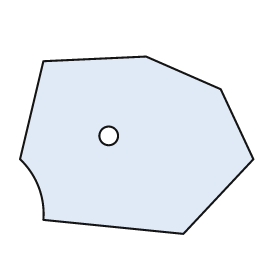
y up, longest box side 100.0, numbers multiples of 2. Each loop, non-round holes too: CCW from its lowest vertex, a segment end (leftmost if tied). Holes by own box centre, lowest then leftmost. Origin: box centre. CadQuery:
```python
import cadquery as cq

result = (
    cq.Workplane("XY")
    .moveTo(20.0, -38.0)
    .lineTo(50.0, -6.0)
    .lineTo(36.0, 24.0)
    .lineTo(4.0, 38.0)
    .lineTo(-40.0, 36.0)
    .lineTo(-50.0, -6.0)
    .threePointArc((-42.0, -18.0), (-40.0, -32.0))
    .close()
    .moveTo(-12.0, 4.0)
    .circle(4.0)
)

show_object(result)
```